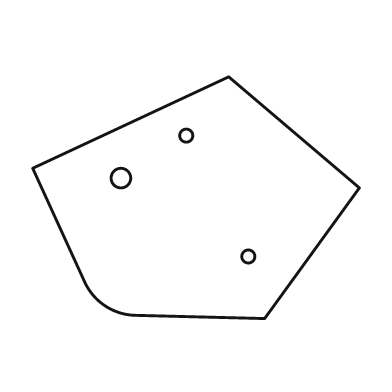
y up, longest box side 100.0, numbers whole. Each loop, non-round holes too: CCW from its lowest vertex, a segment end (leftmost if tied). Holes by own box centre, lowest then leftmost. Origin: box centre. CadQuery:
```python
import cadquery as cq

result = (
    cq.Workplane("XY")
    .moveTo(21.0, -37.0)
    .lineTo(50.0, 3.0)
    .lineTo(10.0, 37.0)
    .lineTo(-50.0, 9.0)
    .lineTo(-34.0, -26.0)
    .threePointArc((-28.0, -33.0), (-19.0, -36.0))
    .close()
    .moveTo(16.0, -18.0)
    .circle(2.0)
    .moveTo(-23.0, 6.0)
    .circle(3.0)
    .moveTo(-3.0, 19.0)
    .circle(2.0)
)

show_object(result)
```